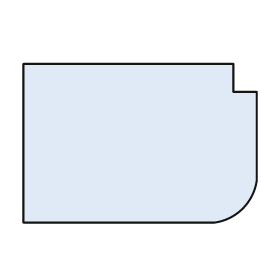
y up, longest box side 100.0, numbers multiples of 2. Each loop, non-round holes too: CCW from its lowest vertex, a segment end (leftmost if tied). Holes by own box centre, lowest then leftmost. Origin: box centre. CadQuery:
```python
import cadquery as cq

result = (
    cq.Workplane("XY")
    .moveTo(-50.0, -34.0)
    .lineTo(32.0, -34.0)
    .threePointArc((44.0, -28.0), (50.0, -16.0))
    .lineTo(50.0, 22.0)
    .lineTo(40.0, 22.0)
    .lineTo(40.0, 34.0)
    .lineTo(-50.0, 34.0)
    .close()
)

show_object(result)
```